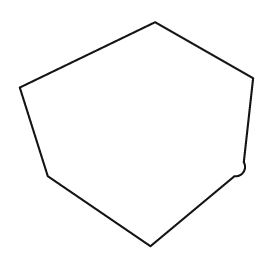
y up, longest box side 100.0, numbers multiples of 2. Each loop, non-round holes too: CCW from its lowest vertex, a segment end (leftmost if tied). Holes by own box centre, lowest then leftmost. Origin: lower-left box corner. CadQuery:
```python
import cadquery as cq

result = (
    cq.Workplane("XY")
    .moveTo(56.0, 0.0)
    .lineTo(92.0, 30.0)
    .threePointArc((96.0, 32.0), (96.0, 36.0))
    .lineTo(100.0, 72.0)
    .lineTo(58.0, 96.0)
    .lineTo(0.0, 68.0)
    .lineTo(12.0, 30.0)
    .close()
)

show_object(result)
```